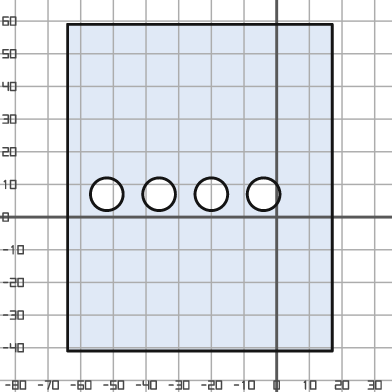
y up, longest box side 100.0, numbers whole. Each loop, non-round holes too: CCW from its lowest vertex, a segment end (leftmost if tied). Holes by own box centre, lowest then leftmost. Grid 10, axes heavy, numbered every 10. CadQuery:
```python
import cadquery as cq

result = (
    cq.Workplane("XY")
    .moveTo(-64.0, -41.0)
    .lineTo(17.0, -41.0)
    .lineTo(17.0, 59.0)
    .lineTo(-64.0, 59.0)
    .close()
    .moveTo(-52.0, 7.0)
    .circle(5.0)
    .moveTo(-36.0, 7.0)
    .circle(5.0)
    .moveTo(-20.0, 7.0)
    .circle(5.0)
    .moveTo(-4.0, 7.0)
    .circle(5.0)
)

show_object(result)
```